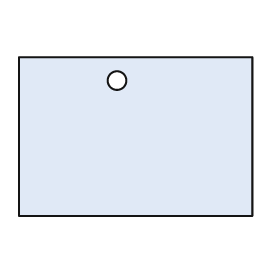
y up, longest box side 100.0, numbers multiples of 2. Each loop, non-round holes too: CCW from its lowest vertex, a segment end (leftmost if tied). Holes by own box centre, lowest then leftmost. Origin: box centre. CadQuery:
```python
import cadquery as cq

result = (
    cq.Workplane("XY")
    .moveTo(-50.0, -34.0)
    .lineTo(50.0, -34.0)
    .lineTo(50.0, 34.0)
    .lineTo(-50.0, 34.0)
    .close()
    .moveTo(-8.0, 24.0)
    .circle(4.0)
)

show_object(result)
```